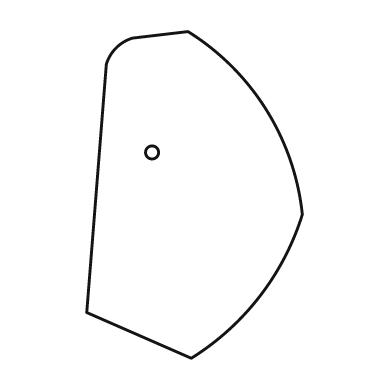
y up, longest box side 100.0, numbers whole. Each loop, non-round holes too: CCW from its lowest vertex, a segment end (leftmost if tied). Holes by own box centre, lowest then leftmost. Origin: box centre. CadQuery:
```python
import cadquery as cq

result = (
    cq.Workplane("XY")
    .moveTo(-1.0, -50.0)
    .threePointArc((20.0, -31.0), (33.0, -6.0))
    .threePointArc((22.0, 26.0), (-2.0, 50.0))
    .lineTo(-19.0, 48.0)
    .threePointArc((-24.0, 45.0), (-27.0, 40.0))
    .lineTo(-33.0, -36.0)
    .close()
    .moveTo(-13.0, 13.0)
    .circle(2.0)
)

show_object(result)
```